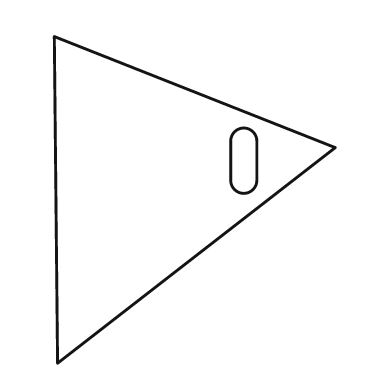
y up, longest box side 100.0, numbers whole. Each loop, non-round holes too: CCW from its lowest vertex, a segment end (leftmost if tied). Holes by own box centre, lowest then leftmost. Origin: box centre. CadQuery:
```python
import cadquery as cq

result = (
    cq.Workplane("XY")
    .moveTo(-42.0, -50.0)
    .lineTo(43.0, 16.0)
    .lineTo(-43.0, 50.0)
    .close()
    .moveTo(11.0, 6.0)
    .threePointArc((15.0, 2.0), (19.0, 6.0))
    .lineTo(19.0, 18.0)
    .threePointArc((15.0, 22.0), (11.0, 18.0))
    .close()
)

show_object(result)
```